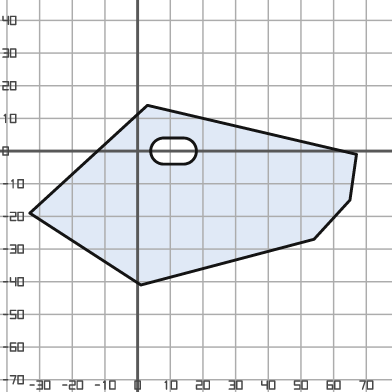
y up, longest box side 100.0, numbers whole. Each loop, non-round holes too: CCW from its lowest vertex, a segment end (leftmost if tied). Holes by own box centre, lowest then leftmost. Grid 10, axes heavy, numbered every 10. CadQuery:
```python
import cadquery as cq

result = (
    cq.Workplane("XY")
    .moveTo(1.0, -41.0)
    .lineTo(54.0, -27.0)
    .lineTo(65.0, -15.0)
    .lineTo(67.0, -1.0)
    .lineTo(3.0, 14.0)
    .lineTo(-33.0, -19.0)
    .close()
    .moveTo(8.0, -4.0)
    .lineTo(14.0, -4.0)
    .threePointArc((18.0, 0.0), (14.0, 4.0))
    .lineTo(8.0, 4.0)
    .threePointArc((4.0, 0.0), (8.0, -4.0))
    .close()
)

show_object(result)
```